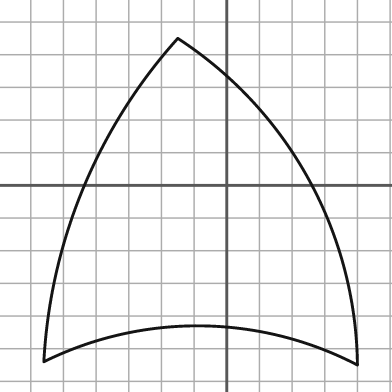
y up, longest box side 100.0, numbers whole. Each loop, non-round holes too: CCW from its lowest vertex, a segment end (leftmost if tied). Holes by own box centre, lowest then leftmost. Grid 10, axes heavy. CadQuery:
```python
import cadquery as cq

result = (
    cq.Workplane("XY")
    .moveTo(40.0, -55.0)
    .threePointArc((25.0, 2.0), (-15.0, 45.0))
    .threePointArc((-44.0, -1.0), (-56.0, -54.0))
    .threePointArc((-8.0, -43.0), (40.0, -55.0))
    .close()
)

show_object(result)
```